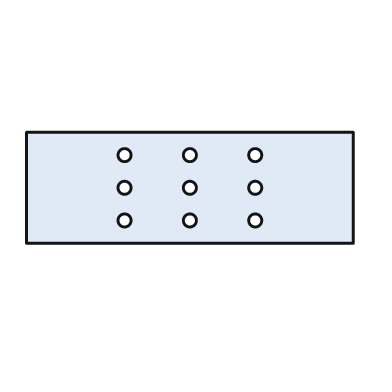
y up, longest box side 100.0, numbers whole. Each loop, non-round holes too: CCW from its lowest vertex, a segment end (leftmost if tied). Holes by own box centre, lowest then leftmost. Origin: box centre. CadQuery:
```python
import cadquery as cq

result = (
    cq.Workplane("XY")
    .moveTo(-50.0, -17.0)
    .lineTo(50.0, -17.0)
    .lineTo(50.0, 17.0)
    .lineTo(-50.0, 17.0)
    .close()
    .moveTo(-20.0, -10.0)
    .circle(2.0)
    .moveTo(0.0, -10.0)
    .circle(2.0)
    .moveTo(20.0, -10.0)
    .circle(2.0)
    .moveTo(-20.0, 0.0)
    .circle(2.0)
    .moveTo(0.0, 0.0)
    .circle(2.0)
    .moveTo(20.0, 0.0)
    .circle(2.0)
    .moveTo(-20.0, 10.0)
    .circle(2.0)
    .moveTo(0.0, 10.0)
    .circle(2.0)
    .moveTo(20.0, 10.0)
    .circle(2.0)
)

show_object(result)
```